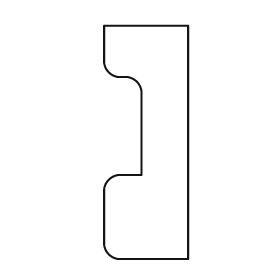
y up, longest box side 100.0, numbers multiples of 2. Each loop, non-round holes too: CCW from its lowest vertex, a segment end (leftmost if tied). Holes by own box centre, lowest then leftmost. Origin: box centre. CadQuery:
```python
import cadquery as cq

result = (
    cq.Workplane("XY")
    .moveTo(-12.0, -50.0)
    .lineTo(18.0, -50.0)
    .lineTo(18.0, 50.0)
    .lineTo(-18.0, 50.0)
    .lineTo(-18.0, 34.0)
    .threePointArc((-16.0, 30.0), (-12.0, 28.0))
    .lineTo(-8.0, 28.0)
    .threePointArc((-4.0, 26.0), (-2.0, 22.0))
    .lineTo(-2.0, -14.0)
    .lineTo(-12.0, -14.0)
    .threePointArc((-16.0, -16.0), (-18.0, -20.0))
    .lineTo(-18.0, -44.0)
    .threePointArc((-16.0, -48.0), (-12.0, -50.0))
    .close()
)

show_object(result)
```